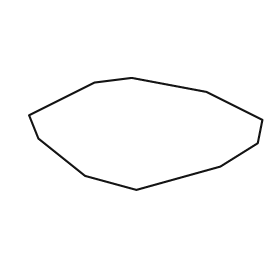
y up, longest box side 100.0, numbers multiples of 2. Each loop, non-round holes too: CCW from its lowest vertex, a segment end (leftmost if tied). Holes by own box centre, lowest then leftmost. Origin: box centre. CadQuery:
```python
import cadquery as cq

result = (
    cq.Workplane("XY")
    .moveTo(-4.0, -24.0)
    .lineTo(32.0, -14.0)
    .lineTo(48.0, -4.0)
    .lineTo(50.0, 6.0)
    .lineTo(26.0, 18.0)
    .lineTo(-6.0, 24.0)
    .lineTo(-22.0, 22.0)
    .lineTo(-50.0, 8.0)
    .lineTo(-46.0, -2.0)
    .lineTo(-26.0, -18.0)
    .close()
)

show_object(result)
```